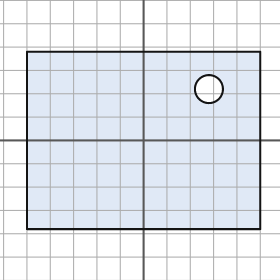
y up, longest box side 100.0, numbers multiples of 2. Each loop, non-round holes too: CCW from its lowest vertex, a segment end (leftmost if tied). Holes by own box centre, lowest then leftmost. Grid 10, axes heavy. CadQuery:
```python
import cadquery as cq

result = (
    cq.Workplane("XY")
    .moveTo(-50.0, -38.0)
    .lineTo(50.0, -38.0)
    .lineTo(50.0, 38.0)
    .lineTo(-50.0, 38.0)
    .close()
    .moveTo(28.0, 22.0)
    .circle(6.0)
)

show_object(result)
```